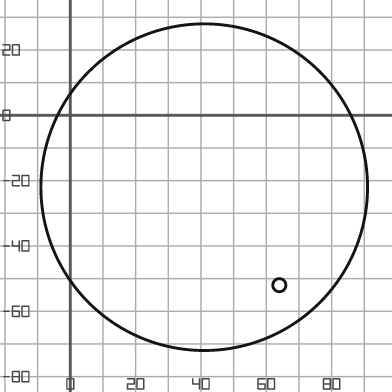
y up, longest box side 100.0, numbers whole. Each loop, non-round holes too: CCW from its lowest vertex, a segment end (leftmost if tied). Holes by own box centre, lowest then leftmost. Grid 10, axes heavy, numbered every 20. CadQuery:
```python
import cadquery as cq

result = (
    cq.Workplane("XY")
    .moveTo(41.0, -22.0)
    .circle(50.0)
    .moveTo(64.0, -52.0)
    .circle(2.0)
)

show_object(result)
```